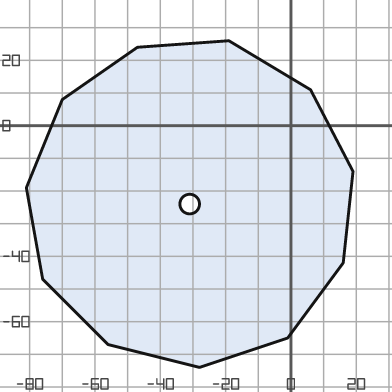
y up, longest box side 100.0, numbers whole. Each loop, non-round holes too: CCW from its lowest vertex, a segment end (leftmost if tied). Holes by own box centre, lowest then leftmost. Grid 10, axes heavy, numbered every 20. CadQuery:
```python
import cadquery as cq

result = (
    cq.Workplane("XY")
    .moveTo(-28.0, -74.0)
    .lineTo(-1.0, -65.0)
    .lineTo(16.0, -42.0)
    .lineTo(19.0, -14.0)
    .lineTo(6.0, 11.0)
    .lineTo(-19.0, 26.0)
    .lineTo(-47.0, 24.0)
    .lineTo(-70.0, 8.0)
    .lineTo(-81.0, -19.0)
    .lineTo(-76.0, -47.0)
    .lineTo(-56.0, -67.0)
    .close()
    .moveTo(-31.0, -24.0)
    .circle(3.0)
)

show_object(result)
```